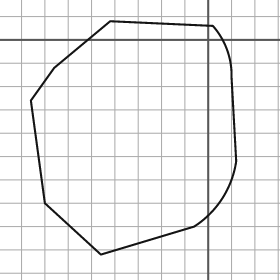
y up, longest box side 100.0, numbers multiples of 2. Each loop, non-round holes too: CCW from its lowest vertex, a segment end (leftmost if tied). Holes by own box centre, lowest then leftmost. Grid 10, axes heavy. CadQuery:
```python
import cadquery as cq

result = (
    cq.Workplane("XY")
    .moveTo(-46.0, -92.0)
    .lineTo(-6.0, -80.0)
    .threePointArc((6.0, -68.0), (12.0, -52.0))
    .lineTo(10.0, -16.0)
    .threePointArc((8.0, -4.0), (2.0, 6.0))
    .lineTo(-42.0, 8.0)
    .lineTo(-66.0, -12.0)
    .lineTo(-76.0, -26.0)
    .lineTo(-70.0, -70.0)
    .close()
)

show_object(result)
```